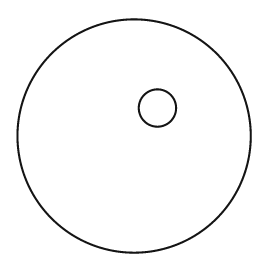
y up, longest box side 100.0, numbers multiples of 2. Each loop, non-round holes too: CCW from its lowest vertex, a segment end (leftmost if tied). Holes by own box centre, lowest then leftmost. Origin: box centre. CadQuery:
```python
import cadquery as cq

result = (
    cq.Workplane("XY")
    .moveTo(0.0, 0.0)
    .circle(50.0)
    .moveTo(10.0, 12.0)
    .circle(8.0)
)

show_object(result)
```